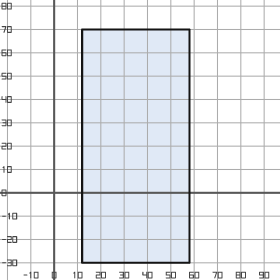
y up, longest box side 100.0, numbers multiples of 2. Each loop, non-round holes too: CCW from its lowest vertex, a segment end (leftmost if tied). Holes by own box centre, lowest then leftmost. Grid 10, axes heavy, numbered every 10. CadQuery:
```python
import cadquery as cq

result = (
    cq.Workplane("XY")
    .moveTo(12.0, -30.0)
    .lineTo(58.0, -30.0)
    .lineTo(58.0, 70.0)
    .lineTo(12.0, 70.0)
    .close()
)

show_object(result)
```